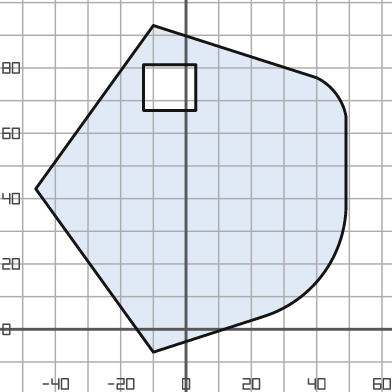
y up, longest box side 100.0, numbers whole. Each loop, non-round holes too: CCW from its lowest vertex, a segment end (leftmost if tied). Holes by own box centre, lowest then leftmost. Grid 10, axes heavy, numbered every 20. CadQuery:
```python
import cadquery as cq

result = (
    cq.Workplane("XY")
    .moveTo(-10.0, -7.0)
    .lineTo(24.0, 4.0)
    .threePointArc((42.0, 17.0), (49.0, 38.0))
    .lineTo(49.0, 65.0)
    .threePointArc((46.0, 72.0), (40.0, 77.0))
    .lineTo(-10.0, 93.0)
    .lineTo(-46.0, 43.0)
    .close()
    .moveTo(-13.0, 67.0)
    .lineTo(3.0, 67.0)
    .lineTo(3.0, 81.0)
    .lineTo(-13.0, 81.0)
    .close()
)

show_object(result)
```